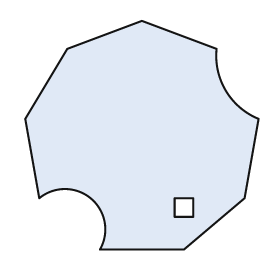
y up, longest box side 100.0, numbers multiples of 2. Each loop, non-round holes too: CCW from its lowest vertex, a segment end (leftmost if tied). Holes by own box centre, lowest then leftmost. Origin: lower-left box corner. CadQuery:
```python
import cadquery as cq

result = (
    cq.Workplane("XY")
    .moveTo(32.0, 0.0)
    .lineTo(68.0, 0.0)
    .lineTo(94.0, 22.0)
    .lineTo(100.0, 56.0)
    .threePointArc((86.0, 68.0), (82.0, 86.0))
    .lineTo(50.0, 98.0)
    .lineTo(18.0, 86.0)
    .lineTo(0.0, 56.0)
    .lineTo(6.0, 22.0)
    .threePointArc((28.0, 22.0), (32.0, 0.0))
    .close()
    .moveTo(64.0, 14.0)
    .lineTo(72.0, 14.0)
    .lineTo(72.0, 22.0)
    .lineTo(64.0, 22.0)
    .close()
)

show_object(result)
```